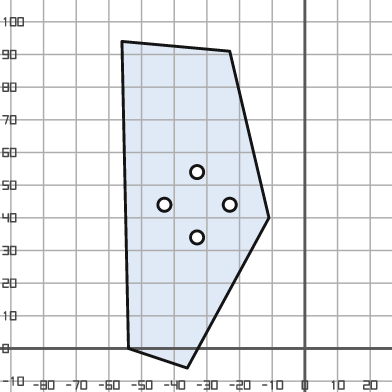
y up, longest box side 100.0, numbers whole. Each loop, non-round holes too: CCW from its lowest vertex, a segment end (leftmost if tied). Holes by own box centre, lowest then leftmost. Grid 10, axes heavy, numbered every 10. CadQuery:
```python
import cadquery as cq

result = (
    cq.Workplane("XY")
    .moveTo(-36.0, -6.0)
    .lineTo(-11.0, 40.0)
    .lineTo(-23.0, 91.0)
    .lineTo(-56.0, 94.0)
    .lineTo(-54.0, 0.0)
    .close()
    .moveTo(-33.0, 34.0)
    .circle(2.0)
    .moveTo(-43.0, 44.0)
    .circle(2.0)
    .moveTo(-23.0, 44.0)
    .circle(2.0)
    .moveTo(-33.0, 54.0)
    .circle(2.0)
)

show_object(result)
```